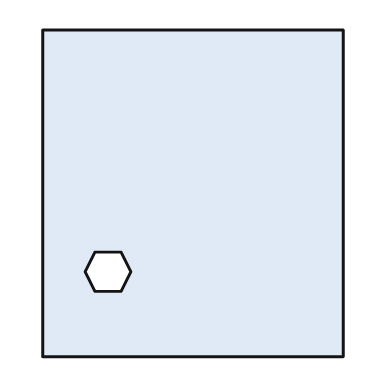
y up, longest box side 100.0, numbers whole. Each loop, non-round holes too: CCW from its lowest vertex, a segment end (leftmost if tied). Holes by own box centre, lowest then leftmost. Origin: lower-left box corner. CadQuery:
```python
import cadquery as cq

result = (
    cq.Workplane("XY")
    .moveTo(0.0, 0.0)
    .lineTo(92.0, 0.0)
    .lineTo(92.0, 100.0)
    .lineTo(0.0, 100.0)
    .close()
    .moveTo(16.0, 20.0)
    .lineTo(24.0, 20.0)
    .lineTo(27.0, 26.0)
    .lineTo(24.0, 32.0)
    .lineTo(16.0, 32.0)
    .lineTo(13.0, 26.0)
    .close()
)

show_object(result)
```